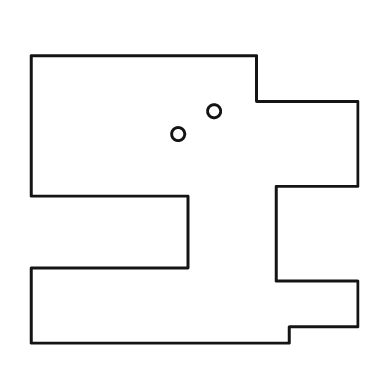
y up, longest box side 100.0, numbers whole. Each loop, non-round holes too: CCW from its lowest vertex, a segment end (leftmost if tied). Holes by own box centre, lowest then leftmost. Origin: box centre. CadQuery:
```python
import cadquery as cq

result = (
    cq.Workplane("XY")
    .moveTo(-50.0, -44.0)
    .lineTo(29.0, -44.0)
    .lineTo(29.0, -39.0)
    .lineTo(50.0, -39.0)
    .lineTo(50.0, -25.0)
    .lineTo(25.0, -25.0)
    .lineTo(25.0, 4.0)
    .lineTo(50.0, 4.0)
    .lineTo(50.0, 30.0)
    .lineTo(19.0, 30.0)
    .lineTo(19.0, 44.0)
    .lineTo(-50.0, 44.0)
    .lineTo(-50.0, 1.0)
    .lineTo(-2.0, 1.0)
    .lineTo(-2.0, -21.0)
    .lineTo(-50.0, -21.0)
    .close()
    .moveTo(-5.0, 20.0)
    .circle(2.0)
    .moveTo(6.0, 27.0)
    .circle(2.0)
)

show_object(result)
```